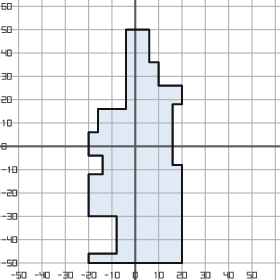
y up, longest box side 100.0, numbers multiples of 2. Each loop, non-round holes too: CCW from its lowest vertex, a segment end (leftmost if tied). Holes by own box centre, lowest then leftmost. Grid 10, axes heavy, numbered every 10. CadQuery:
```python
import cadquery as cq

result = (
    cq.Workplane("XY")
    .moveTo(-20.0, -50.0)
    .lineTo(20.0, -50.0)
    .lineTo(20.0, -8.0)
    .lineTo(16.0, -8.0)
    .lineTo(16.0, 18.0)
    .lineTo(20.0, 18.0)
    .lineTo(20.0, 26.0)
    .lineTo(10.0, 26.0)
    .lineTo(10.0, 36.0)
    .lineTo(6.0, 36.0)
    .lineTo(6.0, 50.0)
    .lineTo(-4.0, 50.0)
    .lineTo(-4.0, 16.0)
    .lineTo(-16.0, 16.0)
    .lineTo(-16.0, 6.0)
    .lineTo(-20.0, 6.0)
    .lineTo(-20.0, -4.0)
    .lineTo(-14.0, -4.0)
    .lineTo(-14.0, -12.0)
    .lineTo(-20.0, -12.0)
    .lineTo(-20.0, -30.0)
    .lineTo(-8.0, -30.0)
    .lineTo(-8.0, -46.0)
    .lineTo(-20.0, -46.0)
    .close()
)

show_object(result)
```